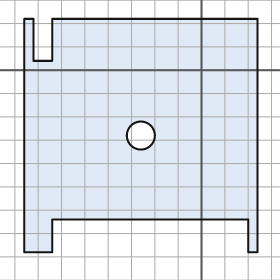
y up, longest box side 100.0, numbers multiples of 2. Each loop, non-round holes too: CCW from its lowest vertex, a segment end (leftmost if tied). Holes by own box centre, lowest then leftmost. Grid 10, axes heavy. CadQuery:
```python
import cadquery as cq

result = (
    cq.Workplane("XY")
    .moveTo(-76.0, -78.0)
    .lineTo(-64.0, -78.0)
    .lineTo(-64.0, -64.0)
    .lineTo(20.0, -64.0)
    .lineTo(20.0, -78.0)
    .lineTo(24.0, -78.0)
    .lineTo(24.0, 22.0)
    .lineTo(-64.0, 22.0)
    .lineTo(-64.0, 4.0)
    .lineTo(-72.0, 4.0)
    .lineTo(-72.0, 22.0)
    .lineTo(-76.0, 22.0)
    .close()
    .moveTo(-26.0, -28.0)
    .circle(6.0)
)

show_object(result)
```